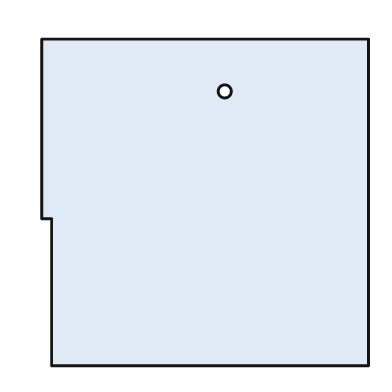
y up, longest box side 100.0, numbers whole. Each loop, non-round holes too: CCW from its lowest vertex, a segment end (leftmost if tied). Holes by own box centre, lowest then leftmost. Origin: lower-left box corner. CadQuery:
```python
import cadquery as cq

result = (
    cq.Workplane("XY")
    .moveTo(3.0, 0.0)
    .lineTo(100.0, 0.0)
    .lineTo(100.0, 100.0)
    .lineTo(0.0, 100.0)
    .lineTo(0.0, 45.0)
    .lineTo(3.0, 45.0)
    .close()
    .moveTo(56.0, 84.0)
    .circle(2.0)
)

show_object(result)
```